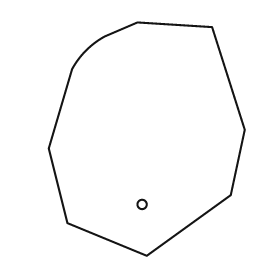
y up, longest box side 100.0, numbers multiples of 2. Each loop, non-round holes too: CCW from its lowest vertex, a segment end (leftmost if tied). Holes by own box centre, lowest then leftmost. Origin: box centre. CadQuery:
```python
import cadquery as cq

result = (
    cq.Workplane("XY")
    .moveTo(0.0, -50.0)
    .lineTo(36.0, -24.0)
    .lineTo(42.0, 4.0)
    .lineTo(28.0, 48.0)
    .lineTo(-4.0, 50.0)
    .lineTo(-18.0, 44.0)
    .threePointArc((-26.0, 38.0), (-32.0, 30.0))
    .lineTo(-42.0, -4.0)
    .lineTo(-34.0, -36.0)
    .close()
    .moveTo(-2.0, -28.0)
    .circle(2.0)
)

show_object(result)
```